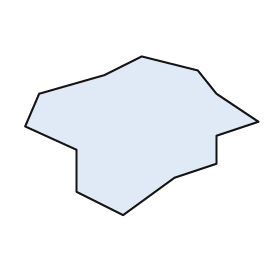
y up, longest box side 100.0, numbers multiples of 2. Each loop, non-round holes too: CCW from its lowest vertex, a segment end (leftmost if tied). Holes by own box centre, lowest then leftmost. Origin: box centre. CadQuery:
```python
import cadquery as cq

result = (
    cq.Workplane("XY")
    .moveTo(-8.0, -34.0)
    .lineTo(14.0, -18.0)
    .lineTo(32.0, -12.0)
    .lineTo(32.0, 0.0)
    .lineTo(50.0, 6.0)
    .lineTo(32.0, 18.0)
    .lineTo(24.0, 28.0)
    .lineTo(0.0, 34.0)
    .lineTo(-16.0, 26.0)
    .lineTo(-44.0, 18.0)
    .lineTo(-50.0, 4.0)
    .lineTo(-28.0, -6.0)
    .lineTo(-28.0, -24.0)
    .close()
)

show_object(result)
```